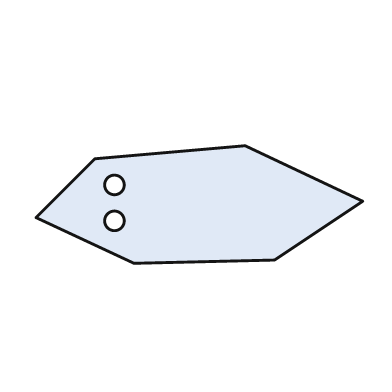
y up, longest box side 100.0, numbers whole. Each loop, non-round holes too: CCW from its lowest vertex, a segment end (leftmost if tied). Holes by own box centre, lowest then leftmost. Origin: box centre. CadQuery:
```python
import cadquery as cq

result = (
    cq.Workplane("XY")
    .moveTo(-20.0, -18.0)
    .lineTo(23.0, -17.0)
    .lineTo(50.0, 1.0)
    .lineTo(14.0, 18.0)
    .lineTo(-32.0, 14.0)
    .lineTo(-50.0, -4.0)
    .close()
    .moveTo(-26.0, -5.0)
    .circle(3.0)
    .moveTo(-26.0, 6.0)
    .circle(3.0)
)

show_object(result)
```